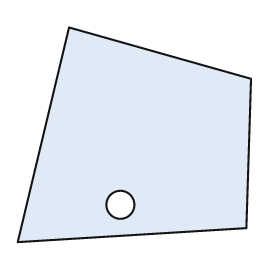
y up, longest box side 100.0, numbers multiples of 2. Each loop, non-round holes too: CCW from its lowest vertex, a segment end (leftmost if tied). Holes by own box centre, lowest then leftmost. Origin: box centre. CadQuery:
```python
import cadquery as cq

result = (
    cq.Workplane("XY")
    .moveTo(-50.0, -46.0)
    .lineTo(48.0, -40.0)
    .lineTo(50.0, 24.0)
    .lineTo(-28.0, 46.0)
    .close()
    .moveTo(-6.0, -30.0)
    .circle(6.0)
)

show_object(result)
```